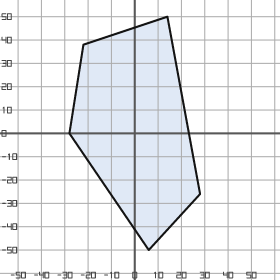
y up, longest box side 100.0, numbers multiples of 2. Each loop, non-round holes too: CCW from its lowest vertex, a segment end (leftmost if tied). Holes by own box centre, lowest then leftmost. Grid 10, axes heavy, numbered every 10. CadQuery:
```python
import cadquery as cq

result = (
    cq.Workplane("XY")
    .moveTo(6.0, -50.0)
    .lineTo(28.0, -26.0)
    .lineTo(14.0, 50.0)
    .lineTo(-22.0, 38.0)
    .lineTo(-28.0, 0.0)
    .close()
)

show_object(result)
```